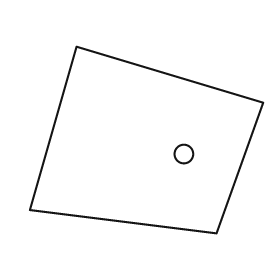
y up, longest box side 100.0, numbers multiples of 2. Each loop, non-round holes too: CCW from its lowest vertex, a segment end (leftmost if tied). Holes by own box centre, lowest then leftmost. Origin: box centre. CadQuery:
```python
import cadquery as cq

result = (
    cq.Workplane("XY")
    .moveTo(30.0, -40.0)
    .lineTo(50.0, 16.0)
    .lineTo(-30.0, 40.0)
    .lineTo(-50.0, -30.0)
    .close()
    .moveTo(16.0, -6.0)
    .circle(4.0)
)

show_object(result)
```